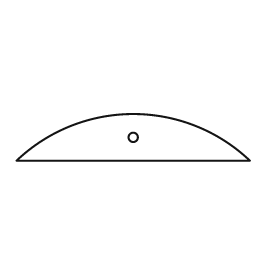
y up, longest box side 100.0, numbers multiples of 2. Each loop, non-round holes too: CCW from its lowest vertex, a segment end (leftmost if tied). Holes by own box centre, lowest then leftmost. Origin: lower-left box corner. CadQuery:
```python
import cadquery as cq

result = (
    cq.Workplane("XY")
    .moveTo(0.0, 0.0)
    .lineTo(100.0, 0.0)
    .threePointArc((50.0, 20.0), (0.0, 0.0))
    .close()
    .moveTo(50.0, 10.0)
    .circle(2.0)
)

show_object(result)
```